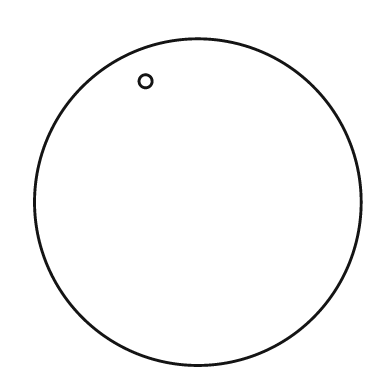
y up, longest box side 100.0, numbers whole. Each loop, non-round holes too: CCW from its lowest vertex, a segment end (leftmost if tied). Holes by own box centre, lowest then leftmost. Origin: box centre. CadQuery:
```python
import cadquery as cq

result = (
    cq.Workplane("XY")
    .moveTo(0.0, 0.0)
    .circle(50.0)
    .moveTo(-16.0, 37.0)
    .circle(2.0)
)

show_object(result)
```